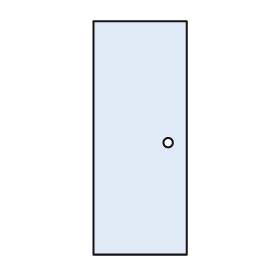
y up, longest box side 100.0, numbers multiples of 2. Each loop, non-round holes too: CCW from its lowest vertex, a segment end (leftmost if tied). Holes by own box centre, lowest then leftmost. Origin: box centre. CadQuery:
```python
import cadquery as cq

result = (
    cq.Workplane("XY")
    .moveTo(-20.0, -50.0)
    .lineTo(20.0, -50.0)
    .lineTo(20.0, 50.0)
    .lineTo(-20.0, 50.0)
    .close()
    .moveTo(12.0, -2.0)
    .circle(2.0)
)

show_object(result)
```